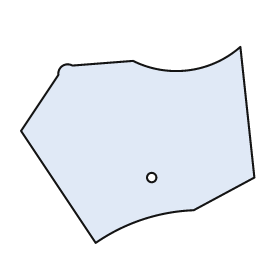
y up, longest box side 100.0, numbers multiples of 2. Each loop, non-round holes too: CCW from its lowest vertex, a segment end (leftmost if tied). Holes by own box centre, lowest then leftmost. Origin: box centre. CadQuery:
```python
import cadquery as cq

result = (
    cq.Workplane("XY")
    .moveTo(-18.0, -42.0)
    .threePointArc((2.0, -32.0), (24.0, -28.0))
    .lineTo(50.0, -14.0)
    .lineTo(44.0, 42.0)
    .threePointArc((22.0, 32.0), (-2.0, 36.0))
    .lineTo(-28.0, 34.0)
    .threePointArc((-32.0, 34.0), (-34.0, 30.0))
    .lineTo(-50.0, 6.0)
    .close()
    .moveTo(6.0, -14.0)
    .circle(2.0)
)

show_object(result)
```